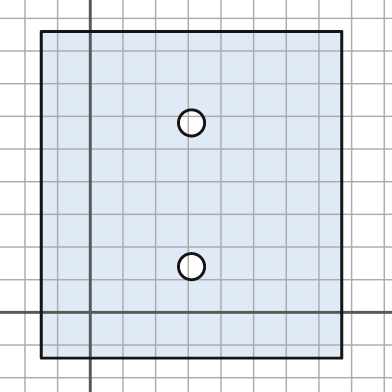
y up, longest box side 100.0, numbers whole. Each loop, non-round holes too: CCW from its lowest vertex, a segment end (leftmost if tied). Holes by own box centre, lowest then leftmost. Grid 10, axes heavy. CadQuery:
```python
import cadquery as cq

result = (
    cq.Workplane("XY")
    .moveTo(-15.0, -14.0)
    .lineTo(77.0, -14.0)
    .lineTo(77.0, 86.0)
    .lineTo(-15.0, 86.0)
    .close()
    .moveTo(31.0, 14.0)
    .circle(4.0)
    .moveTo(31.0, 58.0)
    .circle(4.0)
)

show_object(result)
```